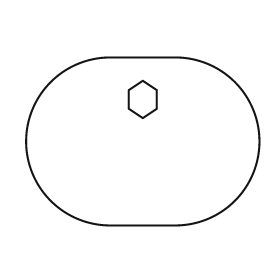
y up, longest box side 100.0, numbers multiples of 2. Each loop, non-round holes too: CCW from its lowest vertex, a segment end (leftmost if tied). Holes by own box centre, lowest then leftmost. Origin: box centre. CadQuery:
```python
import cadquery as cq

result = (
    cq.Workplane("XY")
    .moveTo(-14.0, -36.0)
    .lineTo(14.0, -36.0)
    .threePointArc((50.0, 0.0), (14.0, 36.0))
    .lineTo(-14.0, 36.0)
    .threePointArc((-50.0, 0.0), (-14.0, -36.0))
    .close()
    .moveTo(0.0, 10.0)
    .lineTo(6.0, 14.0)
    .lineTo(6.0, 22.0)
    .lineTo(0.0, 26.0)
    .lineTo(-6.0, 22.0)
    .lineTo(-6.0, 14.0)
    .close()
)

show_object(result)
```